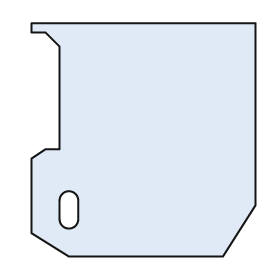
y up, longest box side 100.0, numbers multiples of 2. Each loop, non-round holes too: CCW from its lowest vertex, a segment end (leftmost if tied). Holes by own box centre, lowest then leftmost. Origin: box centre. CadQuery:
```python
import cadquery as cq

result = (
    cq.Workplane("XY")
    .moveTo(-32.0, -50.0)
    .lineTo(34.0, -50.0)
    .lineTo(48.0, -28.0)
    .lineTo(48.0, 50.0)
    .lineTo(-48.0, 50.0)
    .lineTo(-48.0, 46.0)
    .lineTo(-42.0, 46.0)
    .lineTo(-36.0, 40.0)
    .lineTo(-36.0, -4.0)
    .lineTo(-42.0, -4.0)
    .lineTo(-48.0, -8.0)
    .lineTo(-48.0, -40.0)
    .close()
    .moveTo(-36.0, -34.0)
    .threePointArc((-32.0, -38.0), (-28.0, -34.0))
    .lineTo(-28.0, -26.0)
    .threePointArc((-32.0, -22.0), (-36.0, -26.0))
    .close()
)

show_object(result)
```